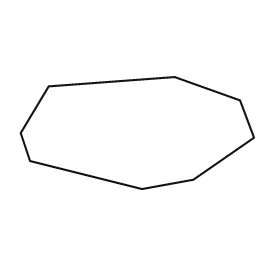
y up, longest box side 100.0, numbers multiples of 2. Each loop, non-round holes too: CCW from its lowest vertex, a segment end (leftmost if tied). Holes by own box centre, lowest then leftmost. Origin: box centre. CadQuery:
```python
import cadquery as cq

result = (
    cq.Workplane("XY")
    .moveTo(2.0, -24.0)
    .lineTo(24.0, -20.0)
    .lineTo(50.0, -2.0)
    .lineTo(44.0, 14.0)
    .lineTo(16.0, 24.0)
    .lineTo(-38.0, 20.0)
    .lineTo(-50.0, 0.0)
    .lineTo(-46.0, -12.0)
    .close()
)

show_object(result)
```